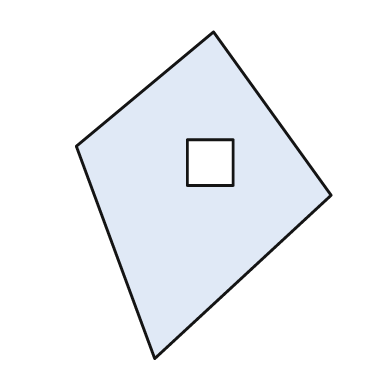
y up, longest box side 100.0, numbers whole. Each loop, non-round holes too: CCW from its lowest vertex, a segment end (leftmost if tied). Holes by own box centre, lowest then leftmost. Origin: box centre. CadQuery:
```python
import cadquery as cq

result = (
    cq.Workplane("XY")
    .moveTo(-15.0, -50.0)
    .lineTo(39.0, 0.0)
    .lineTo(3.0, 50.0)
    .lineTo(-39.0, 15.0)
    .close()
    .moveTo(-5.0, 3.0)
    .lineTo(9.0, 3.0)
    .lineTo(9.0, 17.0)
    .lineTo(-5.0, 17.0)
    .close()
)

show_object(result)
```